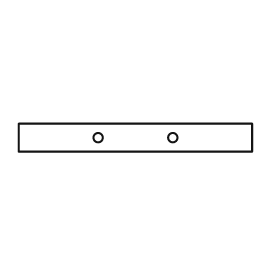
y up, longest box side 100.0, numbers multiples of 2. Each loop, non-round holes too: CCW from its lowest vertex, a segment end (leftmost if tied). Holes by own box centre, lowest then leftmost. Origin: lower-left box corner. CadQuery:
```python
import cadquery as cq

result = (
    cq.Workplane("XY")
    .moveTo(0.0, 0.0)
    .lineTo(100.0, 0.0)
    .lineTo(100.0, 12.0)
    .lineTo(0.0, 12.0)
    .close()
    .moveTo(34.0, 6.0)
    .circle(2.0)
    .moveTo(66.0, 6.0)
    .circle(2.0)
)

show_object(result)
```